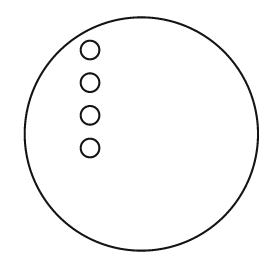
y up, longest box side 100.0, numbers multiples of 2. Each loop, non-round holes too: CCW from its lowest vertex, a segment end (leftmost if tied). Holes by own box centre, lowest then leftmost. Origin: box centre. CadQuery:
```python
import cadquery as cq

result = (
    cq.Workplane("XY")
    .moveTo(0.0, 0.0)
    .circle(50.0)
    .moveTo(-22.0, -6.0)
    .circle(4.0)
    .moveTo(-22.0, 8.0)
    .circle(4.0)
    .moveTo(-22.0, 22.0)
    .circle(4.0)
    .moveTo(-22.0, 36.0)
    .circle(4.0)
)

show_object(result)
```